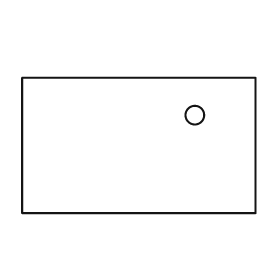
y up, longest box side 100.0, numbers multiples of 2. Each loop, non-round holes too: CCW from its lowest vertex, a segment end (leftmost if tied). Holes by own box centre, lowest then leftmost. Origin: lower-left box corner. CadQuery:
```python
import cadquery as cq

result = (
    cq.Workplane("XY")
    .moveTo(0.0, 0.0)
    .lineTo(100.0, 0.0)
    .lineTo(100.0, 58.0)
    .lineTo(0.0, 58.0)
    .close()
    .moveTo(74.0, 42.0)
    .circle(4.0)
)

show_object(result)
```